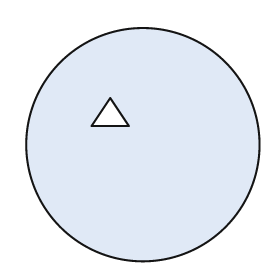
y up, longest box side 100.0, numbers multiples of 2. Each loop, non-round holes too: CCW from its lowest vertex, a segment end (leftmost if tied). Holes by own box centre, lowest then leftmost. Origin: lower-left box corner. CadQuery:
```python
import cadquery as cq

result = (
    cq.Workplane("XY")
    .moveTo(50.0, 50.0)
    .circle(50.0)
    .moveTo(28.0, 58.0)
    .lineTo(44.0, 58.0)
    .lineTo(36.0, 70.0)
    .close()
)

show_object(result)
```